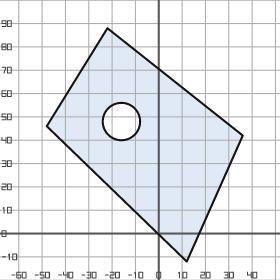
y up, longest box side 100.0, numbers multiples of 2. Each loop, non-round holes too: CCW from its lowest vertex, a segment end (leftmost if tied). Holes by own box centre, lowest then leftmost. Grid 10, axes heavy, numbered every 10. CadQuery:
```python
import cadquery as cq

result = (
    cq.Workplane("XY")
    .moveTo(12.0, -12.0)
    .lineTo(36.0, 42.0)
    .lineTo(-22.0, 88.0)
    .lineTo(-48.0, 46.0)
    .close()
    .moveTo(-16.0, 48.0)
    .circle(8.0)
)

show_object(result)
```